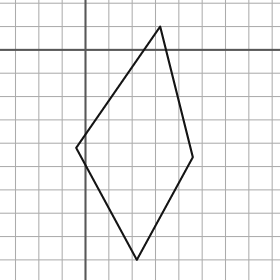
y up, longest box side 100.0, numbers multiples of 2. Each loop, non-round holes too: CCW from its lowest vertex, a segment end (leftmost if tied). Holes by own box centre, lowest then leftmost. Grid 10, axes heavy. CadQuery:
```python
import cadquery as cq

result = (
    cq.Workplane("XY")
    .moveTo(22.0, -90.0)
    .lineTo(46.0, -46.0)
    .lineTo(32.0, 10.0)
    .lineTo(-4.0, -42.0)
    .close()
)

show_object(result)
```